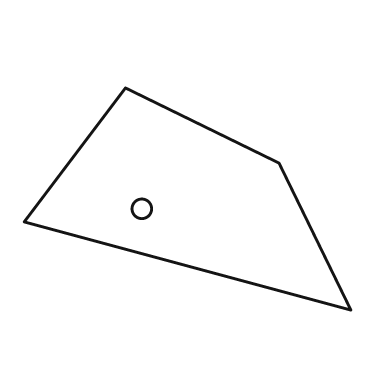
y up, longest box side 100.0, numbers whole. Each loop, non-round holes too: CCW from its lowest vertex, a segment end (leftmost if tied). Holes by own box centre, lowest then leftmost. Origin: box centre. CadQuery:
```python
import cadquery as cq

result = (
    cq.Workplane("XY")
    .moveTo(50.0, -34.0)
    .lineTo(28.0, 11.0)
    .lineTo(-19.0, 34.0)
    .lineTo(-50.0, -7.0)
    .close()
    .moveTo(-14.0, -3.0)
    .circle(3.0)
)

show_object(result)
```